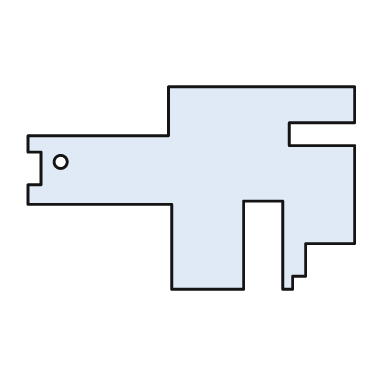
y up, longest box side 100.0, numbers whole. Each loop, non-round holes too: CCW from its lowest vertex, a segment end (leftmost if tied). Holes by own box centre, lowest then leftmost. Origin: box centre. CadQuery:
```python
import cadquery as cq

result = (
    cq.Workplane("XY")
    .moveTo(-6.0, -31.0)
    .lineTo(16.0, -31.0)
    .lineTo(16.0, -4.0)
    .lineTo(28.0, -4.0)
    .lineTo(28.0, -31.0)
    .lineTo(31.0, -31.0)
    .lineTo(31.0, -27.0)
    .lineTo(35.0, -27.0)
    .lineTo(35.0, -17.0)
    .lineTo(50.0, -17.0)
    .lineTo(50.0, 13.0)
    .lineTo(30.0, 13.0)
    .lineTo(30.0, 20.0)
    .lineTo(50.0, 20.0)
    .lineTo(50.0, 31.0)
    .lineTo(-7.0, 31.0)
    .lineTo(-7.0, 16.0)
    .lineTo(-50.0, 16.0)
    .lineTo(-50.0, 11.0)
    .lineTo(-46.0, 11.0)
    .lineTo(-46.0, 1.0)
    .lineTo(-50.0, 1.0)
    .lineTo(-50.0, -5.0)
    .lineTo(-6.0, -5.0)
    .close()
    .moveTo(-40.0, 8.0)
    .circle(2.0)
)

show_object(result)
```